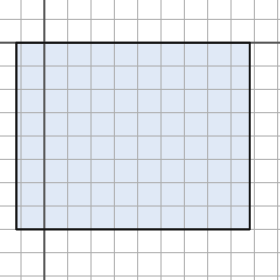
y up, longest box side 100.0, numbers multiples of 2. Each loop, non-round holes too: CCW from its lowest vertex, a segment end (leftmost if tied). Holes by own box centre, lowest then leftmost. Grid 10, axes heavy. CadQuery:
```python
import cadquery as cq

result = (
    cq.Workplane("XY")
    .moveTo(-12.0, -80.0)
    .lineTo(88.0, -80.0)
    .lineTo(88.0, 0.0)
    .lineTo(-12.0, 0.0)
    .close()
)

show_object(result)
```